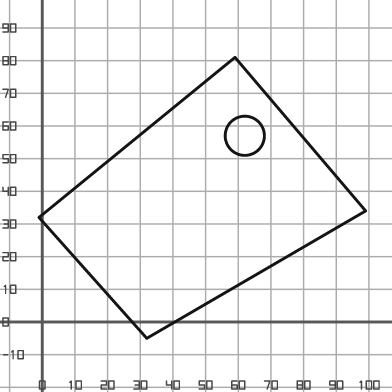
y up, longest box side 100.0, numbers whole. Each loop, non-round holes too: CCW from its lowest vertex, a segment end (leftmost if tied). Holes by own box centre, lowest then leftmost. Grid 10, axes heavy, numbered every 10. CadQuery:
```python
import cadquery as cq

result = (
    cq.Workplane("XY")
    .moveTo(32.0, -5.0)
    .lineTo(99.0, 34.0)
    .lineTo(59.0, 81.0)
    .lineTo(-1.0, 32.0)
    .close()
    .moveTo(62.0, 57.0)
    .circle(6.0)
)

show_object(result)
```